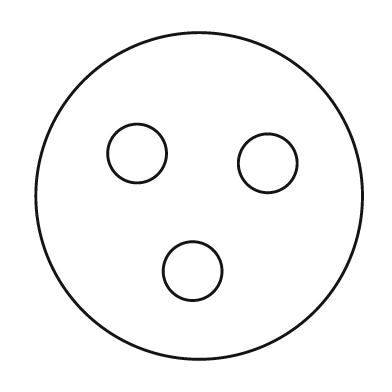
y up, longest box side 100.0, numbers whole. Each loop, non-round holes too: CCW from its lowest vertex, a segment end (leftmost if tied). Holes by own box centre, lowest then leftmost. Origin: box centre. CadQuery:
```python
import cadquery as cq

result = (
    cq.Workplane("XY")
    .moveTo(0.0, 0.0)
    .circle(50.0)
    .moveTo(-2.0, -23.0)
    .circle(9.0)
    .moveTo(21.0, 10.0)
    .circle(9.0)
    .moveTo(-19.0, 13.0)
    .circle(9.0)
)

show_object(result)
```